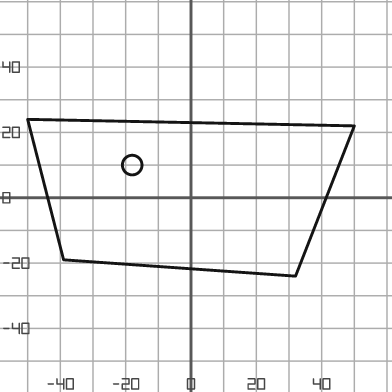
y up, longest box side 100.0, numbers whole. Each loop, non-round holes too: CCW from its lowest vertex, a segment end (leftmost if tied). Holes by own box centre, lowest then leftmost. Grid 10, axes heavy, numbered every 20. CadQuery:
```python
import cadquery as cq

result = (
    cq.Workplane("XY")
    .moveTo(32.0, -24.0)
    .lineTo(50.0, 22.0)
    .lineTo(-50.0, 24.0)
    .lineTo(-39.0, -19.0)
    .close()
    .moveTo(-18.0, 10.0)
    .circle(3.0)
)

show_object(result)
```